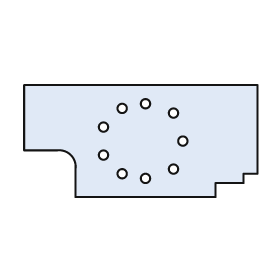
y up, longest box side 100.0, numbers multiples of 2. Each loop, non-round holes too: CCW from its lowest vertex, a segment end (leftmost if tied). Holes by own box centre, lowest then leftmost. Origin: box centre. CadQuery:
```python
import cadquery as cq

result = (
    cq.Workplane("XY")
    .moveTo(-28.0, -24.0)
    .lineTo(32.0, -24.0)
    .lineTo(32.0, -18.0)
    .lineTo(44.0, -18.0)
    .lineTo(44.0, -14.0)
    .lineTo(50.0, -14.0)
    .lineTo(50.0, 24.0)
    .lineTo(-50.0, 24.0)
    .lineTo(-50.0, -4.0)
    .lineTo(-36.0, -4.0)
    .threePointArc((-30.0, -6.0), (-28.0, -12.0))
    .close()
    .moveTo(2.0, -16.0)
    .circle(2.0)
    .moveTo(-8.0, -14.0)
    .circle(2.0)
    .moveTo(14.0, -12.0)
    .circle(2.0)
    .moveTo(-16.0, -6.0)
    .circle(2.0)
    .moveTo(18.0, 0.0)
    .circle(2.0)
    .moveTo(-16.0, 6.0)
    .circle(2.0)
    .moveTo(14.0, 12.0)
    .circle(2.0)
    .moveTo(-8.0, 14.0)
    .circle(2.0)
    .moveTo(2.0, 16.0)
    .circle(2.0)
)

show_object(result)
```